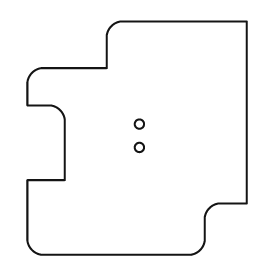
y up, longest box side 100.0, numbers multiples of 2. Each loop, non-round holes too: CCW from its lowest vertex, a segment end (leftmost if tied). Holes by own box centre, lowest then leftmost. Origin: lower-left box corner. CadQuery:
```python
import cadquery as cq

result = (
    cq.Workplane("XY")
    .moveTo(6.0, 0.0)
    .lineTo(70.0, 0.0)
    .threePointArc((74.0, 2.0), (76.0, 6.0))
    .lineTo(76.0, 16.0)
    .threePointArc((78.0, 20.0), (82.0, 22.0))
    .lineTo(94.0, 22.0)
    .lineTo(94.0, 100.0)
    .lineTo(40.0, 100.0)
    .threePointArc((36.0, 98.0), (34.0, 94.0))
    .lineTo(34.0, 80.0)
    .lineTo(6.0, 80.0)
    .threePointArc((2.0, 78.0), (0.0, 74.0))
    .lineTo(0.0, 64.0)
    .lineTo(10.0, 64.0)
    .threePointArc((14.0, 62.0), (16.0, 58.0))
    .lineTo(16.0, 32.0)
    .lineTo(0.0, 32.0)
    .lineTo(0.0, 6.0)
    .threePointArc((2.0, 2.0), (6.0, 0.0))
    .close()
    .moveTo(48.0, 46.0)
    .circle(2.0)
    .moveTo(48.0, 56.0)
    .circle(2.0)
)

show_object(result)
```